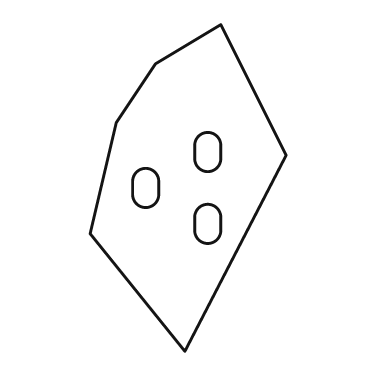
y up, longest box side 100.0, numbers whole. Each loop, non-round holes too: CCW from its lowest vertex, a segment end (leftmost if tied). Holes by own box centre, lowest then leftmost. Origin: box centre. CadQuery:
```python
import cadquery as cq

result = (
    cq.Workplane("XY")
    .moveTo(-1.0, -50.0)
    .lineTo(30.0, 10.0)
    .lineTo(10.0, 50.0)
    .lineTo(-10.0, 38.0)
    .lineTo(-22.0, 20.0)
    .lineTo(-30.0, -14.0)
    .close()
    .moveTo(2.0, -13.0)
    .threePointArc((6.0, -17.0), (10.0, -13.0))
    .lineTo(10.0, -9.0)
    .threePointArc((6.0, -5.0), (2.0, -9.0))
    .close()
    .moveTo(-17.0, -2.0)
    .threePointArc((-13.0, -6.0), (-9.0, -2.0))
    .lineTo(-9.0, 2.0)
    .threePointArc((-13.0, 6.0), (-17.0, 2.0))
    .close()
    .moveTo(2.0, 9.0)
    .threePointArc((6.0, 5.0), (10.0, 9.0))
    .lineTo(10.0, 13.0)
    .threePointArc((6.0, 17.0), (2.0, 13.0))
    .close()
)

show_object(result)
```